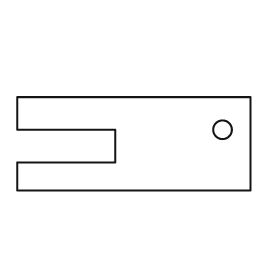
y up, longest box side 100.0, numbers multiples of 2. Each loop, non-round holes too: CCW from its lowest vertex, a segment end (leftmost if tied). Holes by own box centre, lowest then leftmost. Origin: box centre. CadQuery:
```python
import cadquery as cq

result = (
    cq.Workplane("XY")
    .moveTo(-50.0, -20.0)
    .lineTo(50.0, -20.0)
    .lineTo(50.0, 20.0)
    .lineTo(-50.0, 20.0)
    .lineTo(-50.0, 6.0)
    .lineTo(-8.0, 6.0)
    .lineTo(-8.0, -8.0)
    .lineTo(-50.0, -8.0)
    .close()
    .moveTo(38.0, 6.0)
    .circle(4.0)
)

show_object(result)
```